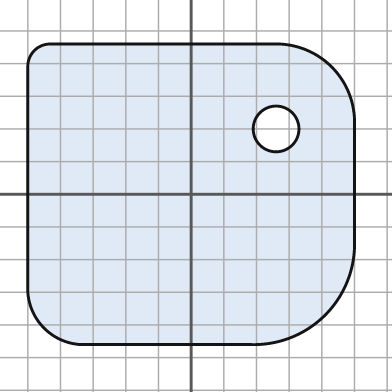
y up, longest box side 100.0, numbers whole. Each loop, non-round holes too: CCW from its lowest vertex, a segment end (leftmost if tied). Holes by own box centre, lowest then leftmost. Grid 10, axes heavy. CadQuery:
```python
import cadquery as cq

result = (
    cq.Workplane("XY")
    .moveTo(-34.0, -46.0)
    .lineTo(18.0, -46.0)
    .threePointArc((41.0, -37.0), (50.0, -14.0))
    .lineTo(50.0, 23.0)
    .threePointArc((43.0, 39.0), (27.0, 46.0))
    .lineTo(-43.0, 46.0)
    .threePointArc((-48.0, 44.0), (-50.0, 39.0))
    .lineTo(-50.0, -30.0)
    .threePointArc((-45.0, -41.0), (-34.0, -46.0))
    .close()
    .moveTo(26.0, 20.0)
    .circle(7.0)
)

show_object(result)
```